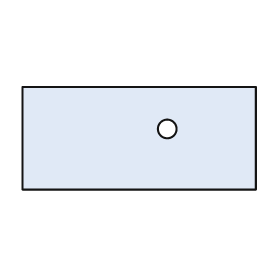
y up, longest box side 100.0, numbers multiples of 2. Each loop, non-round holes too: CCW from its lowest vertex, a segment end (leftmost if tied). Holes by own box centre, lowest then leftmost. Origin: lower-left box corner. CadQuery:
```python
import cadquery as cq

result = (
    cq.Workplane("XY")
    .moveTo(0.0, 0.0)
    .lineTo(100.0, 0.0)
    .lineTo(100.0, 44.0)
    .lineTo(0.0, 44.0)
    .close()
    .moveTo(62.0, 26.0)
    .circle(4.0)
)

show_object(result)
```